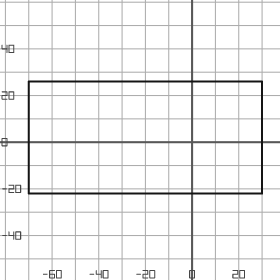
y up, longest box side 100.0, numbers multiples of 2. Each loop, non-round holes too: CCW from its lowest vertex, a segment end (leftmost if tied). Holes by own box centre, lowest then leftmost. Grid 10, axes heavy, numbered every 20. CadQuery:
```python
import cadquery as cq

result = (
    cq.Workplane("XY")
    .moveTo(-70.0, -22.0)
    .lineTo(30.0, -22.0)
    .lineTo(30.0, 26.0)
    .lineTo(-70.0, 26.0)
    .close()
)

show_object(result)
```